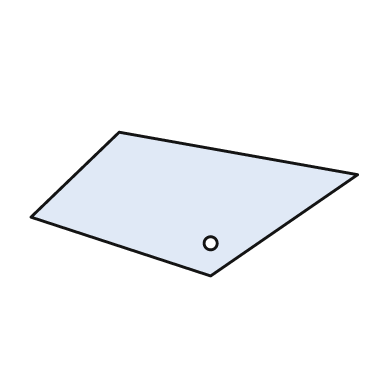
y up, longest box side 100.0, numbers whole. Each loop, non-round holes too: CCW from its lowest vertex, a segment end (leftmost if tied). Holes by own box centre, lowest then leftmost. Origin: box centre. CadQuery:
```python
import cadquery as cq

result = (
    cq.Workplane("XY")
    .moveTo(5.0, -22.0)
    .lineTo(50.0, 9.0)
    .lineTo(-23.0, 22.0)
    .lineTo(-50.0, -4.0)
    .close()
    .moveTo(5.0, -12.0)
    .circle(2.0)
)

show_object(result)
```